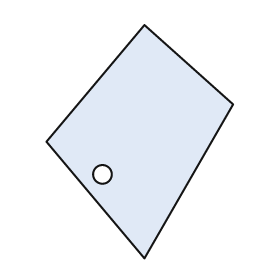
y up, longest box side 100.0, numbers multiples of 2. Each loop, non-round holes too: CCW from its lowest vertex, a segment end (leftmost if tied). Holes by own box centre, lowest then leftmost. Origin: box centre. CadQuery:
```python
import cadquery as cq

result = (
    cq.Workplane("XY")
    .moveTo(2.0, -50.0)
    .lineTo(40.0, 16.0)
    .lineTo(2.0, 50.0)
    .lineTo(-40.0, 0.0)
    .close()
    .moveTo(-16.0, -14.0)
    .circle(4.0)
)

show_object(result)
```